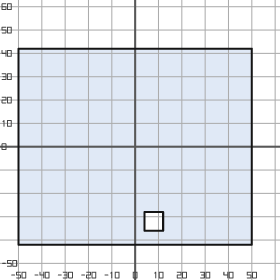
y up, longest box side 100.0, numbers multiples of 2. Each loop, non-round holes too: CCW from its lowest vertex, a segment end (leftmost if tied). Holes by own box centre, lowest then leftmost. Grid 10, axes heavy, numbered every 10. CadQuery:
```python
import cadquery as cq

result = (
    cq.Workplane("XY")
    .moveTo(-50.0, -42.0)
    .lineTo(50.0, -42.0)
    .lineTo(50.0, 42.0)
    .lineTo(-50.0, 42.0)
    .close()
    .moveTo(4.0, -36.0)
    .lineTo(12.0, -36.0)
    .lineTo(12.0, -28.0)
    .lineTo(4.0, -28.0)
    .close()
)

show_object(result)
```